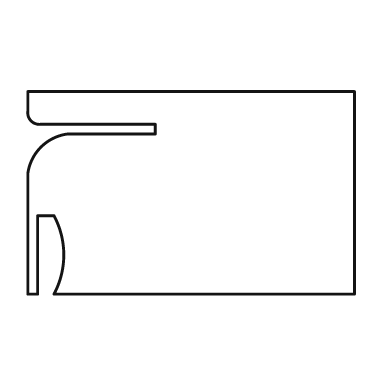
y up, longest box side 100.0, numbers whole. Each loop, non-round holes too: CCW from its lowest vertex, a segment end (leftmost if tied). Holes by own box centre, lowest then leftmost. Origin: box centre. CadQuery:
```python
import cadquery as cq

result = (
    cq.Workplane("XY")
    .moveTo(-50.0, -31.0)
    .lineTo(-47.0, -31.0)
    .lineTo(-47.0, -7.0)
    .lineTo(-42.0, -7.0)
    .threePointArc((-39.0, -19.0), (-42.0, -31.0))
    .lineTo(50.0, -31.0)
    .lineTo(50.0, 31.0)
    .lineTo(-50.0, 31.0)
    .lineTo(-50.0, 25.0)
    .threePointArc((-49.0, 22.0), (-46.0, 21.0))
    .lineTo(-11.0, 21.0)
    .lineTo(-11.0, 18.0)
    .lineTo(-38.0, 18.0)
    .threePointArc((-46.0, 14.0), (-50.0, 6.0))
    .close()
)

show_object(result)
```